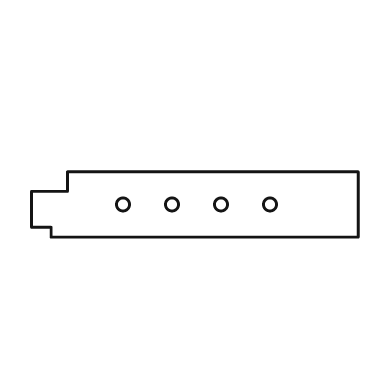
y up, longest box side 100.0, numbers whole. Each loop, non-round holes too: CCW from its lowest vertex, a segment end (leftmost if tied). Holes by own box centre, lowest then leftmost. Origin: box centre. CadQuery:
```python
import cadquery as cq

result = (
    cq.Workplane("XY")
    .moveTo(-44.0, -10.0)
    .lineTo(50.0, -10.0)
    .lineTo(50.0, 10.0)
    .lineTo(-39.0, 10.0)
    .lineTo(-39.0, 4.0)
    .lineTo(-50.0, 4.0)
    .lineTo(-50.0, -7.0)
    .lineTo(-44.0, -7.0)
    .close()
    .moveTo(-22.0, 0.0)
    .circle(2.0)
    .moveTo(-7.0, 0.0)
    .circle(2.0)
    .moveTo(8.0, 0.0)
    .circle(2.0)
    .moveTo(23.0, 0.0)
    .circle(2.0)
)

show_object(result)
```